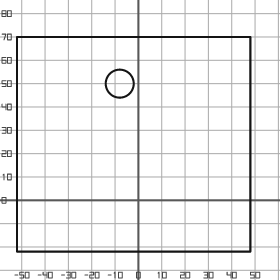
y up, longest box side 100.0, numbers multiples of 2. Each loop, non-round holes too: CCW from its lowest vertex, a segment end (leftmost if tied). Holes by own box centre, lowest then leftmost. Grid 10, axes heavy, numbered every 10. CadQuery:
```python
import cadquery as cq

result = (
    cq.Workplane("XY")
    .moveTo(-52.0, -22.0)
    .lineTo(48.0, -22.0)
    .lineTo(48.0, 70.0)
    .lineTo(-52.0, 70.0)
    .close()
    .moveTo(-8.0, 50.0)
    .circle(6.0)
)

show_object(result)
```